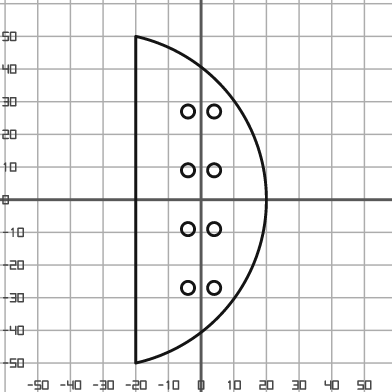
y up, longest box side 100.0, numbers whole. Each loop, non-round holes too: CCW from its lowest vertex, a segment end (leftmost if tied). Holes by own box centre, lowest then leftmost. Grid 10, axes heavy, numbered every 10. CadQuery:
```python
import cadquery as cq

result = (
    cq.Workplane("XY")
    .moveTo(-20.0, -50.0)
    .threePointArc((20.0, 0.0), (-20.0, 50.0))
    .close()
    .moveTo(-4.0, -27.0)
    .circle(2.0)
    .moveTo(4.0, -27.0)
    .circle(2.0)
    .moveTo(-4.0, -9.0)
    .circle(2.0)
    .moveTo(4.0, -9.0)
    .circle(2.0)
    .moveTo(-4.0, 9.0)
    .circle(2.0)
    .moveTo(4.0, 9.0)
    .circle(2.0)
    .moveTo(-4.0, 27.0)
    .circle(2.0)
    .moveTo(4.0, 27.0)
    .circle(2.0)
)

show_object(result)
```